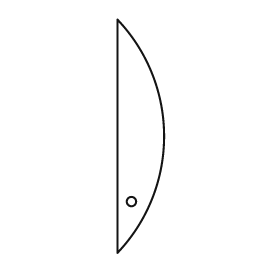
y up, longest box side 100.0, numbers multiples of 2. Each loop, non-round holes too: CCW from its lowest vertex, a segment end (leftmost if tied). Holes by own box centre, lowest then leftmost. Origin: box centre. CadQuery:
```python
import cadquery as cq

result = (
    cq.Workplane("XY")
    .moveTo(-10.0, -50.0)
    .threePointArc((10.0, 0.0), (-10.0, 50.0))
    .close()
    .moveTo(-4.0, -28.0)
    .circle(2.0)
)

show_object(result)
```